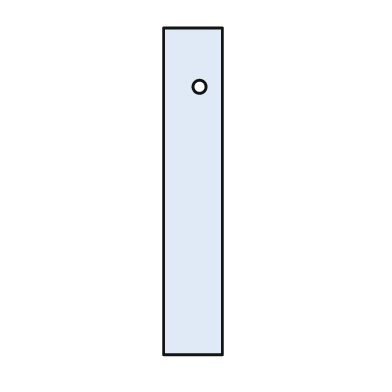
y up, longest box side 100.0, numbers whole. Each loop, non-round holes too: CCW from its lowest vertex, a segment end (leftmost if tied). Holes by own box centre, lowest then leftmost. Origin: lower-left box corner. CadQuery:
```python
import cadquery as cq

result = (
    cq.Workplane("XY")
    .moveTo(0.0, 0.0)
    .lineTo(18.0, 0.0)
    .lineTo(18.0, 100.0)
    .lineTo(0.0, 100.0)
    .close()
    .moveTo(11.0, 82.0)
    .circle(2.0)
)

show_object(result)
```